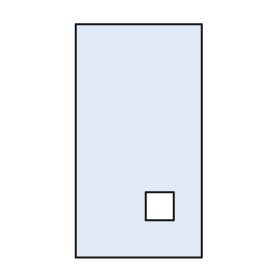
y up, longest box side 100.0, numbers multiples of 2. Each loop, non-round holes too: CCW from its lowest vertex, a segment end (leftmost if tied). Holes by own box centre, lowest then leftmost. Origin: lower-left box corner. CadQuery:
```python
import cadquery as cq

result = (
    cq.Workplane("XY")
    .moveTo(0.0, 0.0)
    .lineTo(54.0, 0.0)
    .lineTo(54.0, 100.0)
    .lineTo(0.0, 100.0)
    .close()
    .moveTo(30.0, 16.0)
    .lineTo(42.0, 16.0)
    .lineTo(42.0, 28.0)
    .lineTo(30.0, 28.0)
    .close()
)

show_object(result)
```